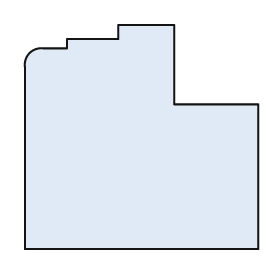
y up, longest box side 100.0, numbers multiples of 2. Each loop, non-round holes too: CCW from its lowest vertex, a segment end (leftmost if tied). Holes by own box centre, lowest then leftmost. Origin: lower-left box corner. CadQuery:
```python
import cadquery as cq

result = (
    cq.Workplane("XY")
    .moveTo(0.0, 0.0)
    .lineTo(100.0, 0.0)
    .lineTo(100.0, 62.0)
    .lineTo(64.0, 62.0)
    .lineTo(64.0, 96.0)
    .lineTo(40.0, 96.0)
    .lineTo(40.0, 90.0)
    .lineTo(18.0, 90.0)
    .lineTo(18.0, 86.0)
    .lineTo(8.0, 86.0)
    .threePointArc((2.0, 84.0), (0.0, 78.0))
    .close()
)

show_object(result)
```